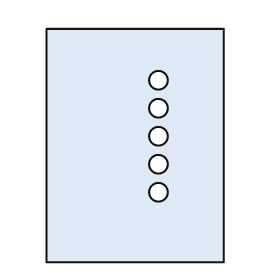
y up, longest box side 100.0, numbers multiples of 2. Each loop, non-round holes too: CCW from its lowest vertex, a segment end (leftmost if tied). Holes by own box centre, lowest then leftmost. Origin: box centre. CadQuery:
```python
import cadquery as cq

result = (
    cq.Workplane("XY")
    .moveTo(-38.0, -50.0)
    .lineTo(38.0, -50.0)
    .lineTo(38.0, 50.0)
    .lineTo(-38.0, 50.0)
    .close()
    .moveTo(10.0, -20.0)
    .circle(4.0)
    .moveTo(10.0, -8.0)
    .circle(4.0)
    .moveTo(10.0, 4.0)
    .circle(4.0)
    .moveTo(10.0, 16.0)
    .circle(4.0)
    .moveTo(10.0, 28.0)
    .circle(4.0)
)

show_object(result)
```